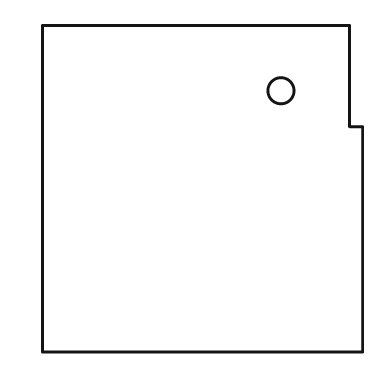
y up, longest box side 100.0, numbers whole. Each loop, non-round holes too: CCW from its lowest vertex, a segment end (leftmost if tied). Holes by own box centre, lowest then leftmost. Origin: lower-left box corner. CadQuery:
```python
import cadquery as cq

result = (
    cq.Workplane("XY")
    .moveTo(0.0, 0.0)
    .lineTo(98.0, 0.0)
    .lineTo(98.0, 69.0)
    .lineTo(94.0, 69.0)
    .lineTo(94.0, 100.0)
    .lineTo(0.0, 100.0)
    .close()
    .moveTo(73.0, 80.0)
    .circle(4.0)
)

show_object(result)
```